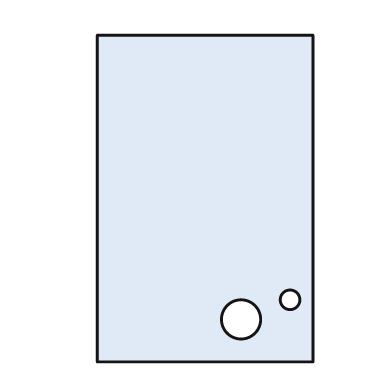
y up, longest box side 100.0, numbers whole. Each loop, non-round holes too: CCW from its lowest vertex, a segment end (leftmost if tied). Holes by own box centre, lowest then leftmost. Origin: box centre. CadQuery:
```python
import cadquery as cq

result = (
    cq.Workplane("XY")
    .moveTo(-33.0, -50.0)
    .lineTo(33.0, -50.0)
    .lineTo(33.0, 50.0)
    .lineTo(-33.0, 50.0)
    .close()
    .moveTo(11.0, -37.0)
    .circle(6.0)
    .moveTo(26.0, -31.0)
    .circle(3.0)
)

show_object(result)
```